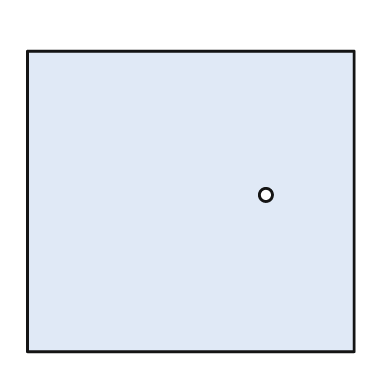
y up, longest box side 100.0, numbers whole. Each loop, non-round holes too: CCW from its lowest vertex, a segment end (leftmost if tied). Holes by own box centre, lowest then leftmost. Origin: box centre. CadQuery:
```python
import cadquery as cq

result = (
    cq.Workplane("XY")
    .moveTo(-50.0, -46.0)
    .lineTo(50.0, -46.0)
    .lineTo(50.0, 46.0)
    .lineTo(-50.0, 46.0)
    .close()
    .moveTo(23.0, 2.0)
    .circle(2.0)
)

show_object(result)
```